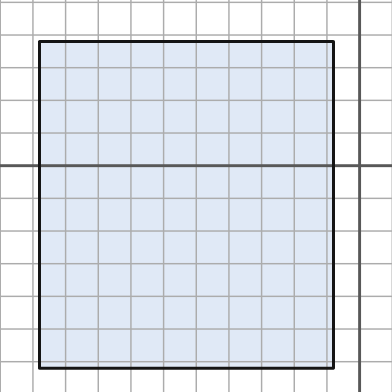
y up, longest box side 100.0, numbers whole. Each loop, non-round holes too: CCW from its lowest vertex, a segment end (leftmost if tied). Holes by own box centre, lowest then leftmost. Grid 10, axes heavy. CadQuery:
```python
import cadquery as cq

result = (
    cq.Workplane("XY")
    .moveTo(-98.0, -62.0)
    .lineTo(-8.0, -62.0)
    .lineTo(-8.0, 38.0)
    .lineTo(-98.0, 38.0)
    .close()
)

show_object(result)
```